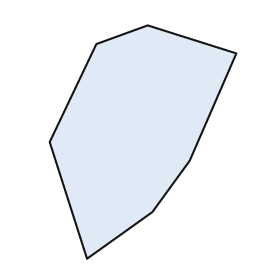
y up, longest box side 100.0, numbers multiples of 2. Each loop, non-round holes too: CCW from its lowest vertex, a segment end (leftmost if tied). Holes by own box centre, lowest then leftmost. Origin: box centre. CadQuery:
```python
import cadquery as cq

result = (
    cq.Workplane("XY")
    .moveTo(-24.0, -50.0)
    .lineTo(4.0, -30.0)
    .lineTo(20.0, -8.0)
    .lineTo(40.0, 38.0)
    .lineTo(2.0, 50.0)
    .lineTo(-20.0, 42.0)
    .lineTo(-40.0, 0.0)
    .close()
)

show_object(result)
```